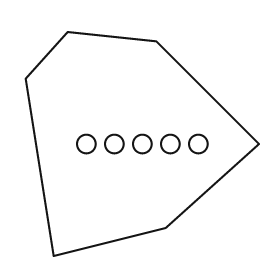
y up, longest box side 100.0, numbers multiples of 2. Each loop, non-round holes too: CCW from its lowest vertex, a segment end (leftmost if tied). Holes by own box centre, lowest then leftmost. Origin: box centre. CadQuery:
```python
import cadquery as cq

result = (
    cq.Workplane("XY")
    .moveTo(-38.0, -48.0)
    .lineTo(10.0, -36.0)
    .lineTo(50.0, 0.0)
    .lineTo(6.0, 44.0)
    .lineTo(-32.0, 48.0)
    .lineTo(-50.0, 28.0)
    .close()
    .moveTo(-24.0, 0.0)
    .circle(4.0)
    .moveTo(-12.0, 0.0)
    .circle(4.0)
    .moveTo(0.0, 0.0)
    .circle(4.0)
    .moveTo(12.0, 0.0)
    .circle(4.0)
    .moveTo(24.0, 0.0)
    .circle(4.0)
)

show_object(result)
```